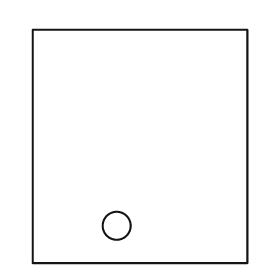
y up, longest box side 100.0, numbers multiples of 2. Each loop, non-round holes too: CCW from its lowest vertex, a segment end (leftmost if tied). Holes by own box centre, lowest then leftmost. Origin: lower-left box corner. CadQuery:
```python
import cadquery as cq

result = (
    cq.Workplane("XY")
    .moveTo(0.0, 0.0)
    .lineTo(92.0, 0.0)
    .lineTo(92.0, 100.0)
    .lineTo(0.0, 100.0)
    .close()
    .moveTo(36.0, 16.0)
    .circle(6.0)
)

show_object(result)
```